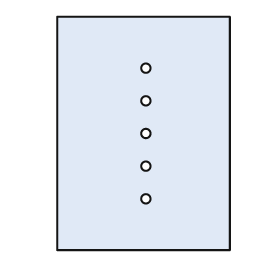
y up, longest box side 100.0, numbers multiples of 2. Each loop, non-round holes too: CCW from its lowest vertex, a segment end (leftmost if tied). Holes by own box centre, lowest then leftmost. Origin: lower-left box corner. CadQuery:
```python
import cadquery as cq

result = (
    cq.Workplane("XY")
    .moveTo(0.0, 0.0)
    .lineTo(74.0, 0.0)
    .lineTo(74.0, 100.0)
    .lineTo(0.0, 100.0)
    .close()
    .moveTo(38.0, 22.0)
    .circle(2.0)
    .moveTo(38.0, 36.0)
    .circle(2.0)
    .moveTo(38.0, 50.0)
    .circle(2.0)
    .moveTo(38.0, 64.0)
    .circle(2.0)
    .moveTo(38.0, 78.0)
    .circle(2.0)
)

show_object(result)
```